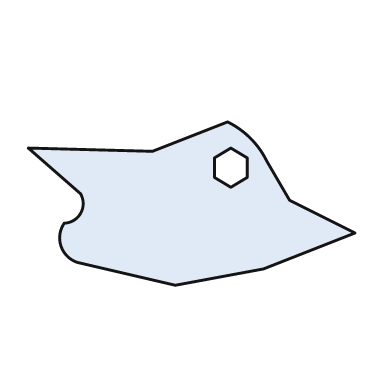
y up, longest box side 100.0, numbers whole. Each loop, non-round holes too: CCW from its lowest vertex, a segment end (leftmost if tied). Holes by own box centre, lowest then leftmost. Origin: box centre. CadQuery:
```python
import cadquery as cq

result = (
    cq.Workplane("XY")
    .moveTo(-5.0, -25.0)
    .lineTo(22.0, -20.0)
    .lineTo(50.0, -9.0)
    .lineTo(30.0, 1.0)
    .lineTo(23.0, 13.0)
    .threePointArc((18.0, 20.0), (11.0, 25.0))
    .lineTo(-12.0, 16.0)
    .lineTo(-50.0, 17.0)
    .lineTo(-34.0, 3.0)
    .threePointArc((-34.0, -3.0), (-39.0, -6.0))
    .threePointArc((-40.0, -13.0), (-35.0, -18.0))
    .close()
    .moveTo(12.0, 5.0)
    .lineTo(17.0, 8.0)
    .lineTo(17.0, 14.0)
    .lineTo(12.0, 17.0)
    .lineTo(7.0, 14.0)
    .lineTo(7.0, 8.0)
    .close()
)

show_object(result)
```